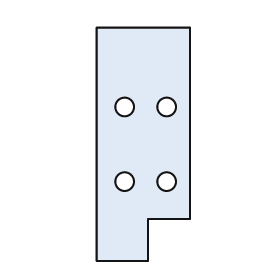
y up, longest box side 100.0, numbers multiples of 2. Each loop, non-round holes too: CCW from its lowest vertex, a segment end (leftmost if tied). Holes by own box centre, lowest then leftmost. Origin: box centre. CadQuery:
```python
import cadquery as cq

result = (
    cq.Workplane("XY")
    .moveTo(-20.0, -50.0)
    .lineTo(2.0, -50.0)
    .lineTo(2.0, -32.0)
    .lineTo(20.0, -32.0)
    .lineTo(20.0, 50.0)
    .lineTo(-20.0, 50.0)
    .close()
    .moveTo(-8.0, -16.0)
    .circle(4.0)
    .moveTo(10.0, -16.0)
    .circle(4.0)
    .moveTo(-8.0, 16.0)
    .circle(4.0)
    .moveTo(10.0, 16.0)
    .circle(4.0)
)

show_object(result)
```